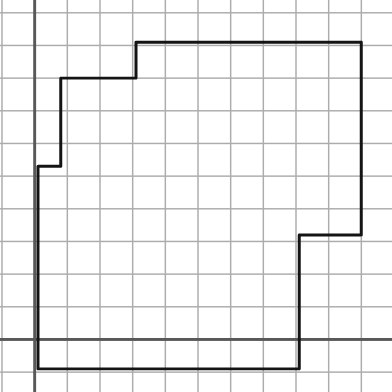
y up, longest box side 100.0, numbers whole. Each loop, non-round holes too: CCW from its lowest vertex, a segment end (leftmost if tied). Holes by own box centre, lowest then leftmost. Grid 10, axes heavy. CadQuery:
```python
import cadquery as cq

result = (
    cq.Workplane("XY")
    .moveTo(1.0, -9.0)
    .lineTo(81.0, -9.0)
    .lineTo(81.0, 32.0)
    .lineTo(100.0, 32.0)
    .lineTo(100.0, 91.0)
    .lineTo(31.0, 91.0)
    .lineTo(31.0, 80.0)
    .lineTo(8.0, 80.0)
    .lineTo(8.0, 53.0)
    .lineTo(1.0, 53.0)
    .close()
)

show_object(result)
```